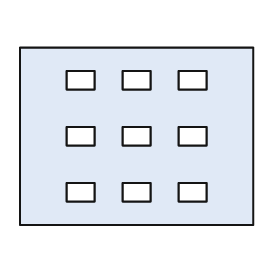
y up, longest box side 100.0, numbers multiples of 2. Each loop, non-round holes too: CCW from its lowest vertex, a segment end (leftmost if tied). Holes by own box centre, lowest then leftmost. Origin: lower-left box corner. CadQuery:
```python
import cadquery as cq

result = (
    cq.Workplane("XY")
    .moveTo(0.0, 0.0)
    .lineTo(100.0, 0.0)
    .lineTo(100.0, 76.0)
    .lineTo(0.0, 76.0)
    .close()
    .moveTo(20.0, 10.0)
    .lineTo(32.0, 10.0)
    .lineTo(32.0, 18.0)
    .lineTo(20.0, 18.0)
    .close()
    .moveTo(44.0, 10.0)
    .lineTo(56.0, 10.0)
    .lineTo(56.0, 18.0)
    .lineTo(44.0, 18.0)
    .close()
    .moveTo(68.0, 10.0)
    .lineTo(80.0, 10.0)
    .lineTo(80.0, 18.0)
    .lineTo(68.0, 18.0)
    .close()
    .moveTo(20.0, 34.0)
    .lineTo(32.0, 34.0)
    .lineTo(32.0, 42.0)
    .lineTo(20.0, 42.0)
    .close()
    .moveTo(44.0, 34.0)
    .lineTo(56.0, 34.0)
    .lineTo(56.0, 42.0)
    .lineTo(44.0, 42.0)
    .close()
    .moveTo(68.0, 34.0)
    .lineTo(80.0, 34.0)
    .lineTo(80.0, 42.0)
    .lineTo(68.0, 42.0)
    .close()
    .moveTo(20.0, 58.0)
    .lineTo(32.0, 58.0)
    .lineTo(32.0, 66.0)
    .lineTo(20.0, 66.0)
    .close()
    .moveTo(44.0, 58.0)
    .lineTo(56.0, 58.0)
    .lineTo(56.0, 66.0)
    .lineTo(44.0, 66.0)
    .close()
    .moveTo(68.0, 58.0)
    .lineTo(80.0, 58.0)
    .lineTo(80.0, 66.0)
    .lineTo(68.0, 66.0)
    .close()
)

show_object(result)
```